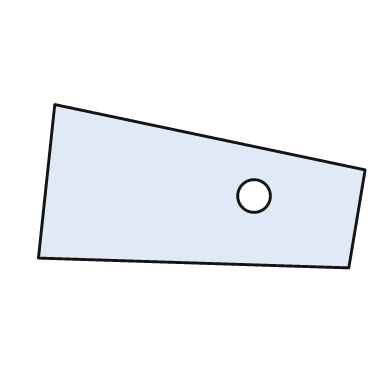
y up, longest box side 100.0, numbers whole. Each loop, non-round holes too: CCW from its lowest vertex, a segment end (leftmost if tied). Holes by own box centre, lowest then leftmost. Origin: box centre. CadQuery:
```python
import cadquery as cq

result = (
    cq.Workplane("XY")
    .moveTo(45.0, -25.0)
    .lineTo(50.0, 5.0)
    .lineTo(-45.0, 25.0)
    .lineTo(-50.0, -22.0)
    .close()
    .moveTo(16.0, -3.0)
    .circle(5.0)
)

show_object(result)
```